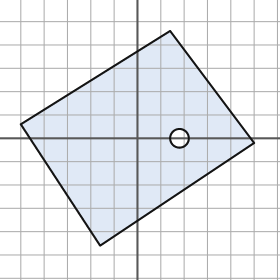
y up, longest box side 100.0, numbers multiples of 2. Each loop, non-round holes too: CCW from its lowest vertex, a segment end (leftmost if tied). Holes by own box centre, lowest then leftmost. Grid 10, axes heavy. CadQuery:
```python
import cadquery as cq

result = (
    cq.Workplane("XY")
    .moveTo(-16.0, -46.0)
    .lineTo(50.0, -2.0)
    .lineTo(14.0, 46.0)
    .lineTo(-50.0, 6.0)
    .close()
    .moveTo(18.0, 0.0)
    .circle(4.0)
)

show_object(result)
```